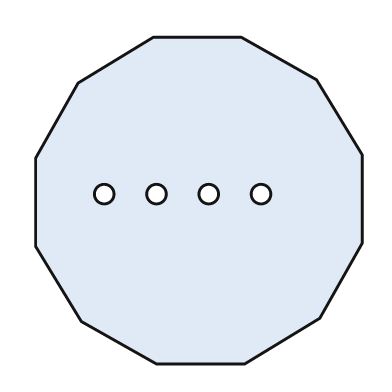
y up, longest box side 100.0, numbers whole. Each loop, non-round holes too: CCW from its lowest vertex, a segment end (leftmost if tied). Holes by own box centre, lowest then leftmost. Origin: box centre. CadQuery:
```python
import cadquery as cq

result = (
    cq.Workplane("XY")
    .moveTo(-13.0, -50.0)
    .lineTo(14.0, -50.0)
    .lineTo(37.0, -36.0)
    .lineTo(50.0, -13.0)
    .lineTo(50.0, 14.0)
    .lineTo(36.0, 37.0)
    .lineTo(13.0, 50.0)
    .lineTo(-14.0, 50.0)
    .lineTo(-37.0, 36.0)
    .lineTo(-50.0, 13.0)
    .lineTo(-50.0, -14.0)
    .lineTo(-36.0, -37.0)
    .close()
    .moveTo(-29.0, 2.0)
    .circle(3.0)
    .moveTo(-13.0, 2.0)
    .circle(3.0)
    .moveTo(3.0, 2.0)
    .circle(3.0)
    .moveTo(19.0, 2.0)
    .circle(3.0)
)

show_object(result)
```